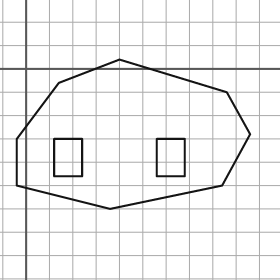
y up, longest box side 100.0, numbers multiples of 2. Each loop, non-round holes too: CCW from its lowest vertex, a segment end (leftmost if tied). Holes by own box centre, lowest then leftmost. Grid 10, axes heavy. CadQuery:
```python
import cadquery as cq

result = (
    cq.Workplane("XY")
    .moveTo(36.0, -60.0)
    .lineTo(84.0, -50.0)
    .lineTo(96.0, -28.0)
    .lineTo(86.0, -10.0)
    .lineTo(40.0, 4.0)
    .lineTo(14.0, -6.0)
    .lineTo(-4.0, -30.0)
    .lineTo(-4.0, -50.0)
    .close()
    .moveTo(12.0, -46.0)
    .lineTo(24.0, -46.0)
    .lineTo(24.0, -30.0)
    .lineTo(12.0, -30.0)
    .close()
    .moveTo(56.0, -46.0)
    .lineTo(68.0, -46.0)
    .lineTo(68.0, -30.0)
    .lineTo(56.0, -30.0)
    .close()
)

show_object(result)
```